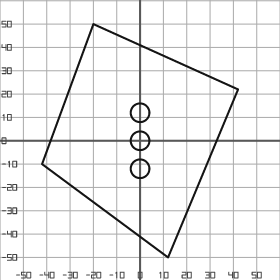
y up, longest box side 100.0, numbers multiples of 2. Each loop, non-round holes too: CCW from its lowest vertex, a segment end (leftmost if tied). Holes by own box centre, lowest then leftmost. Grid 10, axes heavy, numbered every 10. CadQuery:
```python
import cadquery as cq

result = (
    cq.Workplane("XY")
    .moveTo(12.0, -50.0)
    .lineTo(42.0, 22.0)
    .lineTo(-20.0, 50.0)
    .lineTo(-42.0, -10.0)
    .close()
    .moveTo(0.0, -12.0)
    .circle(4.0)
    .moveTo(0.0, 0.0)
    .circle(4.0)
    .moveTo(0.0, 12.0)
    .circle(4.0)
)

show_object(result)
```